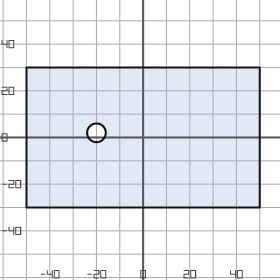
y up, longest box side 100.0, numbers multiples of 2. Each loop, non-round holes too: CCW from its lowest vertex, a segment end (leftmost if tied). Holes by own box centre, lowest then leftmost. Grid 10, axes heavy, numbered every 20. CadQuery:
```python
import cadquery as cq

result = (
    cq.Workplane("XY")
    .moveTo(-50.0, -30.0)
    .lineTo(50.0, -30.0)
    .lineTo(50.0, 30.0)
    .lineTo(-50.0, 30.0)
    .close()
    .moveTo(-20.0, 2.0)
    .circle(4.0)
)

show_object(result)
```